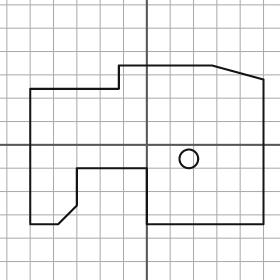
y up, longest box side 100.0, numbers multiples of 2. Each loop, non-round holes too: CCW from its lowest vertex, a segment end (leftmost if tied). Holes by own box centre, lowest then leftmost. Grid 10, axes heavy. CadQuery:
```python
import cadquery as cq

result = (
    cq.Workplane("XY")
    .moveTo(-50.0, -34.0)
    .lineTo(-38.0, -34.0)
    .lineTo(-30.0, -26.0)
    .lineTo(-30.0, -10.0)
    .lineTo(0.0, -10.0)
    .lineTo(0.0, -34.0)
    .lineTo(50.0, -34.0)
    .lineTo(50.0, 28.0)
    .lineTo(28.0, 34.0)
    .lineTo(-12.0, 34.0)
    .lineTo(-12.0, 24.0)
    .lineTo(-50.0, 24.0)
    .close()
    .moveTo(18.0, -6.0)
    .circle(4.0)
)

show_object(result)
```